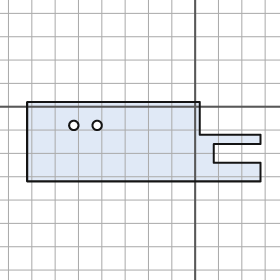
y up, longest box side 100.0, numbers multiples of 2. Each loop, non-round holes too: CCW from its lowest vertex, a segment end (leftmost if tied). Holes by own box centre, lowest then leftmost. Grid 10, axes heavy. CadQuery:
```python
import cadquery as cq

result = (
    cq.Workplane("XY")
    .moveTo(-72.0, -32.0)
    .lineTo(28.0, -32.0)
    .lineTo(28.0, -24.0)
    .lineTo(8.0, -24.0)
    .lineTo(8.0, -16.0)
    .lineTo(28.0, -16.0)
    .lineTo(28.0, -12.0)
    .lineTo(2.0, -12.0)
    .lineTo(2.0, 2.0)
    .lineTo(-72.0, 2.0)
    .close()
    .moveTo(-52.0, -8.0)
    .circle(2.0)
    .moveTo(-42.0, -8.0)
    .circle(2.0)
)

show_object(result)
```